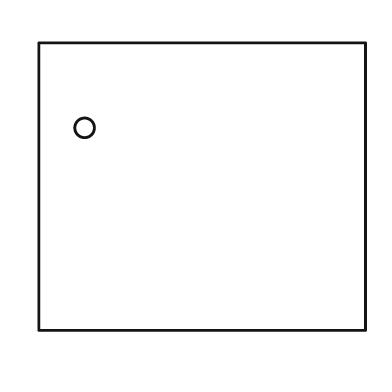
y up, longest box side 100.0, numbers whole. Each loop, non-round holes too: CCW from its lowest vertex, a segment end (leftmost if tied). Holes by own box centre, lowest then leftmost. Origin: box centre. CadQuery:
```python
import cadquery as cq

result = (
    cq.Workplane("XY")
    .moveTo(-50.0, -44.0)
    .lineTo(50.0, -44.0)
    .lineTo(50.0, 44.0)
    .lineTo(-50.0, 44.0)
    .close()
    .moveTo(-36.0, 18.0)
    .circle(3.0)
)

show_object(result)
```